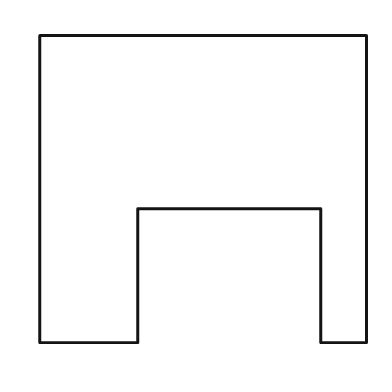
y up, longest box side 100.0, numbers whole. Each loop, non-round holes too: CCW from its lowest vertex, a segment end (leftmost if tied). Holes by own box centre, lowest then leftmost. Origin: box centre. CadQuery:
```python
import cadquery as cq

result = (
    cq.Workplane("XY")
    .moveTo(-50.0, -47.0)
    .lineTo(-20.0, -47.0)
    .lineTo(-20.0, -6.0)
    .lineTo(36.0, -6.0)
    .lineTo(36.0, -47.0)
    .lineTo(50.0, -47.0)
    .lineTo(50.0, 47.0)
    .lineTo(-50.0, 47.0)
    .close()
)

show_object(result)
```